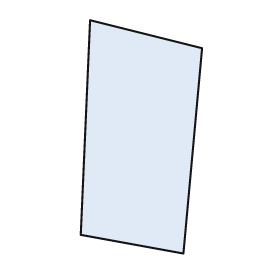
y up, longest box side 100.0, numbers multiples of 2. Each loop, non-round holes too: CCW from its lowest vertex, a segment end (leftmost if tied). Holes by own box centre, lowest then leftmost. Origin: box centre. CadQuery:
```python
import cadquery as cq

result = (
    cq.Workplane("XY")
    .moveTo(18.0, -50.0)
    .lineTo(26.0, 38.0)
    .lineTo(-22.0, 50.0)
    .lineTo(-26.0, -42.0)
    .close()
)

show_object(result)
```